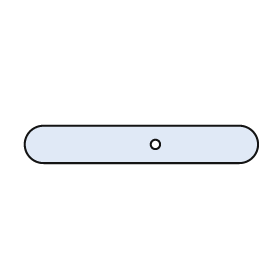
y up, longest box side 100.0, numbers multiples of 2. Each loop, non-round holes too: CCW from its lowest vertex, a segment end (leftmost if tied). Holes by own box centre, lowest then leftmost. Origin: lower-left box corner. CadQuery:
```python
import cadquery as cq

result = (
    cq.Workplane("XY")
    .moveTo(8.0, 0.0)
    .lineTo(92.0, 0.0)
    .threePointArc((100.0, 8.0), (92.0, 16.0))
    .lineTo(8.0, 16.0)
    .threePointArc((0.0, 8.0), (8.0, 0.0))
    .close()
    .moveTo(56.0, 8.0)
    .circle(2.0)
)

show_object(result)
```